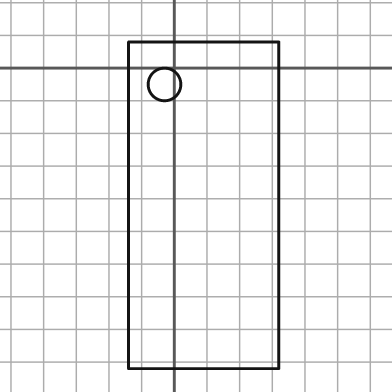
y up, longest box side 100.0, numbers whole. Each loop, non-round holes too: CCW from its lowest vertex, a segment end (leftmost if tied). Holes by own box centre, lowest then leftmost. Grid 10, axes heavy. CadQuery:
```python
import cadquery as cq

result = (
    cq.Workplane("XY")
    .moveTo(-14.0, -92.0)
    .lineTo(32.0, -92.0)
    .lineTo(32.0, 8.0)
    .lineTo(-14.0, 8.0)
    .close()
    .moveTo(-3.0, -5.0)
    .circle(5.0)
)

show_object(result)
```